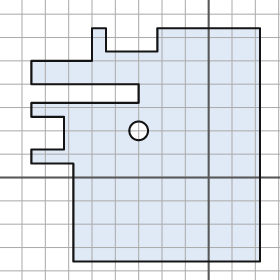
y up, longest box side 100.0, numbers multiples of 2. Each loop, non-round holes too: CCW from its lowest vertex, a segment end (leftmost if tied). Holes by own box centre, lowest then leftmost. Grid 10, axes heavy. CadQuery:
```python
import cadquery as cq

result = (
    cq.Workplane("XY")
    .moveTo(-58.0, -36.0)
    .lineTo(22.0, -36.0)
    .lineTo(22.0, 64.0)
    .lineTo(-22.0, 64.0)
    .lineTo(-22.0, 54.0)
    .lineTo(-44.0, 54.0)
    .lineTo(-44.0, 64.0)
    .lineTo(-50.0, 64.0)
    .lineTo(-50.0, 50.0)
    .lineTo(-76.0, 50.0)
    .lineTo(-76.0, 40.0)
    .lineTo(-30.0, 40.0)
    .lineTo(-30.0, 32.0)
    .lineTo(-76.0, 32.0)
    .lineTo(-76.0, 26.0)
    .lineTo(-62.0, 26.0)
    .lineTo(-62.0, 12.0)
    .lineTo(-76.0, 12.0)
    .lineTo(-76.0, 6.0)
    .lineTo(-58.0, 6.0)
    .close()
    .moveTo(-30.0, 20.0)
    .circle(4.0)
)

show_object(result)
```